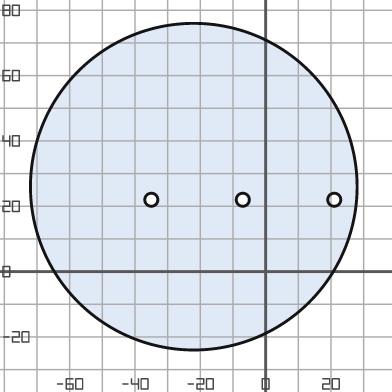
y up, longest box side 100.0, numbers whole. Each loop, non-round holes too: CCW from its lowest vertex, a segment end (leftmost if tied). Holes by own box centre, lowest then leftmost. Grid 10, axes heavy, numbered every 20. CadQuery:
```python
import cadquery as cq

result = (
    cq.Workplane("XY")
    .moveTo(-22.0, 26.0)
    .circle(50.0)
    .moveTo(-35.0, 22.0)
    .circle(2.0)
    .moveTo(-7.0, 22.0)
    .circle(2.0)
    .moveTo(21.0, 22.0)
    .circle(2.0)
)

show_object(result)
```